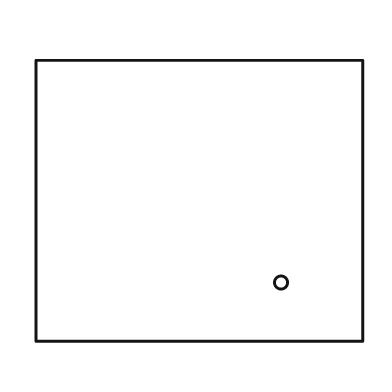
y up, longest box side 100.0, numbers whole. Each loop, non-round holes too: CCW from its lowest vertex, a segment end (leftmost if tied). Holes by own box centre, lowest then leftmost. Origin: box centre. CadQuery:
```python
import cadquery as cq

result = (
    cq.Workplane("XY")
    .moveTo(-50.0, -43.0)
    .lineTo(50.0, -43.0)
    .lineTo(50.0, 43.0)
    .lineTo(-50.0, 43.0)
    .close()
    .moveTo(25.0, -25.0)
    .circle(2.0)
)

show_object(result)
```